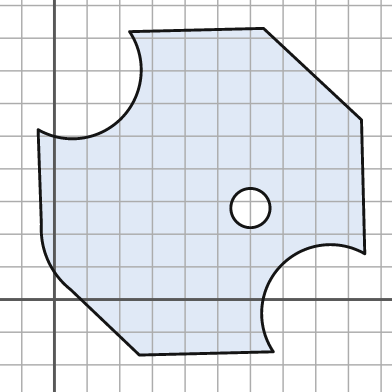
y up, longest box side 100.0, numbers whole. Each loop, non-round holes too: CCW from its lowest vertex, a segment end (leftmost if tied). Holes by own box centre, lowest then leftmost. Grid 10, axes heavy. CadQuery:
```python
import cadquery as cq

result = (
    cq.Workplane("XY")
    .moveTo(26.0, -17.0)
    .lineTo(67.0, -16.0)
    .threePointArc((69.0, 10.0), (95.0, 14.0))
    .lineTo(94.0, 55.0)
    .lineTo(64.0, 83.0)
    .lineTo(23.0, 82.0)
    .threePointArc((21.0, 56.0), (-5.0, 52.0))
    .lineTo(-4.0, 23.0)
    .threePointArc((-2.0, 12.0), (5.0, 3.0))
    .close()
    .moveTo(60.0, 28.0)
    .circle(6.0)
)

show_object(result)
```